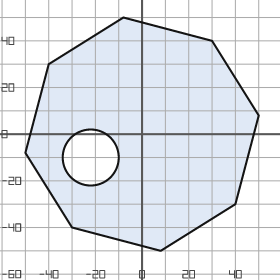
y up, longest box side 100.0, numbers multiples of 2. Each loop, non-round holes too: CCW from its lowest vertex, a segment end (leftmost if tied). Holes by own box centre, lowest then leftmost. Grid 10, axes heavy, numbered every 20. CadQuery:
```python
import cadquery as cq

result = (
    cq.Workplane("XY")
    .moveTo(8.0, -50.0)
    .lineTo(40.0, -30.0)
    .lineTo(50.0, 8.0)
    .lineTo(30.0, 40.0)
    .lineTo(-8.0, 50.0)
    .lineTo(-40.0, 30.0)
    .lineTo(-50.0, -8.0)
    .lineTo(-30.0, -40.0)
    .close()
    .moveTo(-22.0, -10.0)
    .circle(12.0)
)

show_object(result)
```